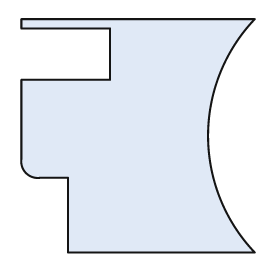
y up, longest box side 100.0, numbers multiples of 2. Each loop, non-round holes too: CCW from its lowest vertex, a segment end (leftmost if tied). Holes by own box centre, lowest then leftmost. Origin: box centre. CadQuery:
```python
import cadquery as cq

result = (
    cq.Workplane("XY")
    .moveTo(-30.0, -50.0)
    .lineTo(50.0, -50.0)
    .threePointArc((30.0, 0.0), (50.0, 50.0))
    .lineTo(-50.0, 50.0)
    .lineTo(-50.0, 46.0)
    .lineTo(-12.0, 46.0)
    .lineTo(-12.0, 24.0)
    .lineTo(-50.0, 24.0)
    .lineTo(-50.0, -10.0)
    .threePointArc((-48.0, -16.0), (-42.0, -18.0))
    .lineTo(-30.0, -18.0)
    .close()
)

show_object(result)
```